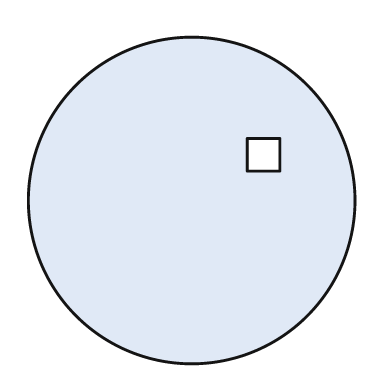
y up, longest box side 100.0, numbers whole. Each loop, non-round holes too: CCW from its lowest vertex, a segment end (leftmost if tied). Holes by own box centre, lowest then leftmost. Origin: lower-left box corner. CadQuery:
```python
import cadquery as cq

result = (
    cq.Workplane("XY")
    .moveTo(50.0, 50.0)
    .circle(50.0)
    .moveTo(67.0, 59.0)
    .lineTo(77.0, 59.0)
    .lineTo(77.0, 69.0)
    .lineTo(67.0, 69.0)
    .close()
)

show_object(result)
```